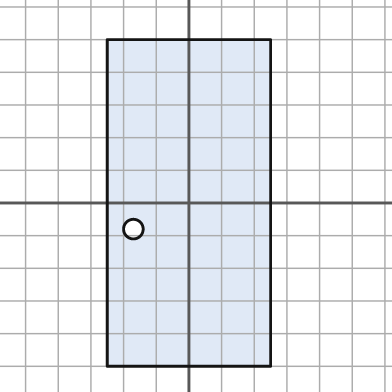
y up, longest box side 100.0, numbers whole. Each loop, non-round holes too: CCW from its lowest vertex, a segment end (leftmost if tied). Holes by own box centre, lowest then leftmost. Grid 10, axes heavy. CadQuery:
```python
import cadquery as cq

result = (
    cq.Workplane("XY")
    .moveTo(-25.0, -50.0)
    .lineTo(25.0, -50.0)
    .lineTo(25.0, 50.0)
    .lineTo(-25.0, 50.0)
    .close()
    .moveTo(-17.0, -8.0)
    .circle(3.0)
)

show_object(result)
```